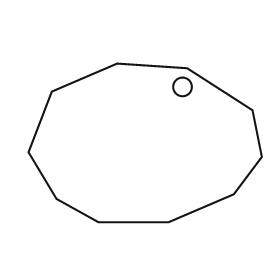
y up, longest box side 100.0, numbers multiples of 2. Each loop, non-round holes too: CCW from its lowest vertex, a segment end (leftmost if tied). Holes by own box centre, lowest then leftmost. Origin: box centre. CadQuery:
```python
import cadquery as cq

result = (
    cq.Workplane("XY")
    .moveTo(-20.0, -34.0)
    .lineTo(10.0, -34.0)
    .lineTo(38.0, -22.0)
    .lineTo(50.0, -6.0)
    .lineTo(46.0, 14.0)
    .lineTo(18.0, 32.0)
    .lineTo(-12.0, 34.0)
    .lineTo(-40.0, 22.0)
    .lineTo(-50.0, -4.0)
    .lineTo(-38.0, -24.0)
    .close()
    .moveTo(16.0, 24.0)
    .circle(4.0)
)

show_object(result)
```